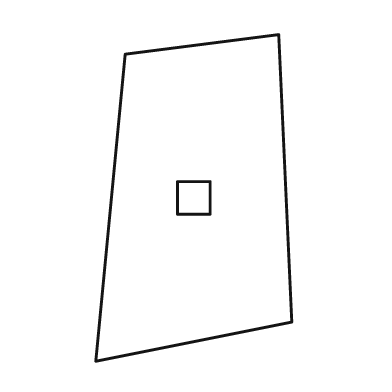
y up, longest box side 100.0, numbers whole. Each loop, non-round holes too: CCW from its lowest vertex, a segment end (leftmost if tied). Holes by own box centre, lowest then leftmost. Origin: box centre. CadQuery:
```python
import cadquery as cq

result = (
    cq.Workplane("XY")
    .moveTo(-30.0, -50.0)
    .lineTo(30.0, -38.0)
    .lineTo(26.0, 50.0)
    .lineTo(-21.0, 44.0)
    .close()
    .moveTo(-5.0, -5.0)
    .lineTo(5.0, -5.0)
    .lineTo(5.0, 5.0)
    .lineTo(-5.0, 5.0)
    .close()
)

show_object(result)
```